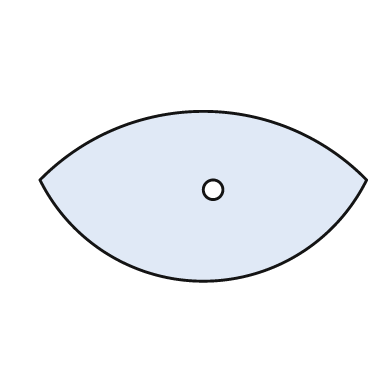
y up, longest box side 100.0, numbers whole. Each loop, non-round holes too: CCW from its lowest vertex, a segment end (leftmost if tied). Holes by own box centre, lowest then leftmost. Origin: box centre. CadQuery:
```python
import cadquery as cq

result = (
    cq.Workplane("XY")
    .moveTo(-50.0, 5.0)
    .threePointArc((0.0, -26.0), (50.0, 5.0))
    .threePointArc((0.0, 26.0), (-50.0, 5.0))
    .close()
    .moveTo(3.0, 2.0)
    .circle(3.0)
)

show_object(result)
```